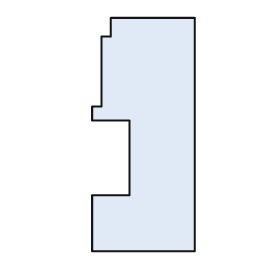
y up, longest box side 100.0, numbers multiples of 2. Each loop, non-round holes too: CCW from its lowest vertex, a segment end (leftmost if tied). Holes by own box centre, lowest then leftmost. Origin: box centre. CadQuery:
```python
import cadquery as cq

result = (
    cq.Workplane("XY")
    .moveTo(-22.0, -50.0)
    .lineTo(22.0, -50.0)
    .lineTo(22.0, 50.0)
    .lineTo(-14.0, 50.0)
    .lineTo(-14.0, 42.0)
    .lineTo(-18.0, 42.0)
    .lineTo(-18.0, 12.0)
    .lineTo(-22.0, 12.0)
    .lineTo(-22.0, 6.0)
    .lineTo(-6.0, 6.0)
    .lineTo(-6.0, -26.0)
    .lineTo(-22.0, -26.0)
    .close()
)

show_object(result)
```